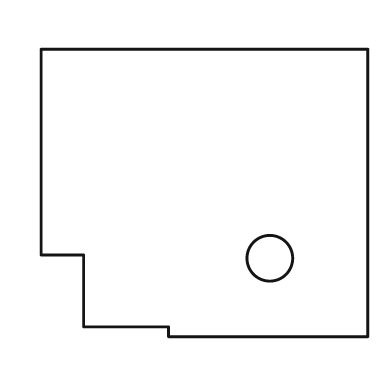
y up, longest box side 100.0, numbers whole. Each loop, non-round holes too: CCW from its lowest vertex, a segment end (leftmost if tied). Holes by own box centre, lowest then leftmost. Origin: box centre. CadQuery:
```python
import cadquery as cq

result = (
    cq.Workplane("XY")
    .moveTo(-11.0, -44.0)
    .lineTo(50.0, -44.0)
    .lineTo(50.0, 44.0)
    .lineTo(-50.0, 44.0)
    .lineTo(-50.0, -19.0)
    .lineTo(-37.0, -19.0)
    .lineTo(-37.0, -41.0)
    .lineTo(-11.0, -41.0)
    .close()
    .moveTo(20.0, -20.0)
    .circle(7.0)
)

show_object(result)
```